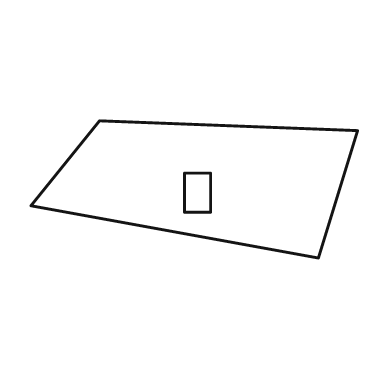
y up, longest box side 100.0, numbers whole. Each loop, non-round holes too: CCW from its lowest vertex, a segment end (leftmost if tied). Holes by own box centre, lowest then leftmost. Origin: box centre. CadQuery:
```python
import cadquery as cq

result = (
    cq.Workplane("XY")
    .moveTo(38.0, -21.0)
    .lineTo(50.0, 18.0)
    .lineTo(-29.0, 21.0)
    .lineTo(-50.0, -5.0)
    .close()
    .moveTo(-3.0, -7.0)
    .lineTo(5.0, -7.0)
    .lineTo(5.0, 5.0)
    .lineTo(-3.0, 5.0)
    .close()
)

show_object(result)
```